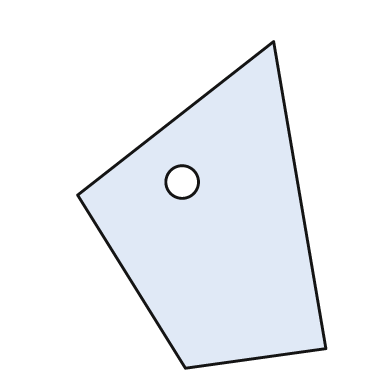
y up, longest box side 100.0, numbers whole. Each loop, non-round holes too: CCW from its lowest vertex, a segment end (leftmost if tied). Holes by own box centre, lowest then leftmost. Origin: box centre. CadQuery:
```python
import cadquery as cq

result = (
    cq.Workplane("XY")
    .moveTo(-5.0, -50.0)
    .lineTo(38.0, -44.0)
    .lineTo(22.0, 50.0)
    .lineTo(-38.0, 3.0)
    .close()
    .moveTo(-6.0, 7.0)
    .circle(5.0)
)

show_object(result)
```